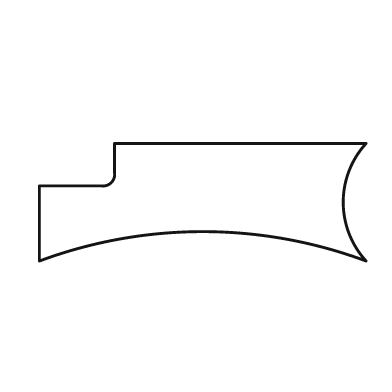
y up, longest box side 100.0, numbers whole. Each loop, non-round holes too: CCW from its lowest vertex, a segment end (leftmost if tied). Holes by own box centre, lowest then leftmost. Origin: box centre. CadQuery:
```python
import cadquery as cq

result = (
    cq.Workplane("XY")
    .moveTo(-50.0, -18.0)
    .threePointArc((0.0, -9.0), (50.0, -18.0))
    .threePointArc((43.0, 0.0), (50.0, 18.0))
    .lineTo(-27.0, 18.0)
    .lineTo(-27.0, 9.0)
    .threePointArc((-28.0, 6.0), (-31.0, 5.0))
    .lineTo(-50.0, 5.0)
    .close()
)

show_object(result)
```